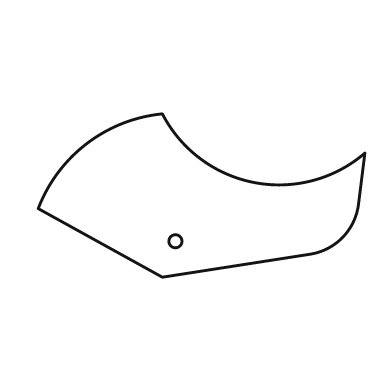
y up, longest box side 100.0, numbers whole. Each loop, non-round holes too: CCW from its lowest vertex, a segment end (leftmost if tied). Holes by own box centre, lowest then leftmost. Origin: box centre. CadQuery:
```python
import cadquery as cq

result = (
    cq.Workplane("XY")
    .moveTo(-12.0, -25.0)
    .lineTo(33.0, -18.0)
    .threePointArc((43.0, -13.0), (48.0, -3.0))
    .lineTo(50.0, 13.0)
    .threePointArc((16.0, 4.0), (-12.0, 25.0))
    .threePointArc((-35.0, 16.0), (-50.0, -4.0))
    .close()
    .moveTo(-8.0, -14.0)
    .circle(2.0)
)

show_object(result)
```